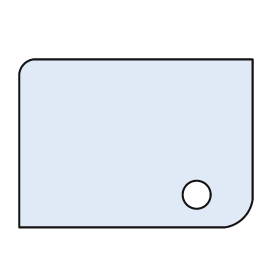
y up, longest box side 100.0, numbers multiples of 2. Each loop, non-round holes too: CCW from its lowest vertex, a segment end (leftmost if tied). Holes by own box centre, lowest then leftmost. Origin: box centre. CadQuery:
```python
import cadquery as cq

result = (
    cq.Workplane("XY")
    .moveTo(-50.0, -36.0)
    .lineTo(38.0, -36.0)
    .threePointArc((46.0, -32.0), (50.0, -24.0))
    .lineTo(50.0, 36.0)
    .lineTo(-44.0, 36.0)
    .threePointArc((-48.0, 34.0), (-50.0, 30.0))
    .close()
    .moveTo(26.0, -22.0)
    .circle(6.0)
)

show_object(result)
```